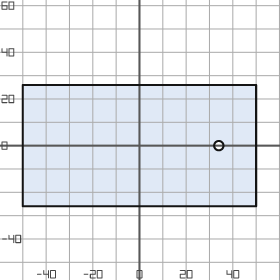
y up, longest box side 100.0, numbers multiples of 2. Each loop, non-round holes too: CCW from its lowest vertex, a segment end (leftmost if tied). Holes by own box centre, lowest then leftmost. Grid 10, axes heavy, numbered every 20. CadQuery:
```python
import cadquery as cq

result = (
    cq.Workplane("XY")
    .moveTo(-50.0, -26.0)
    .lineTo(50.0, -26.0)
    .lineTo(50.0, 26.0)
    .lineTo(-50.0, 26.0)
    .close()
    .moveTo(34.0, 0.0)
    .circle(2.0)
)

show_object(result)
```